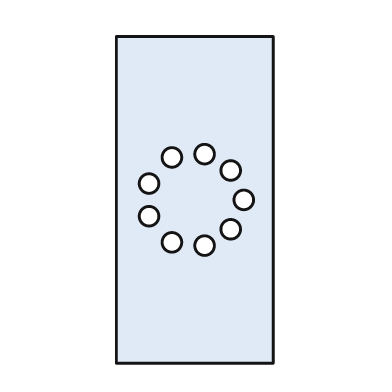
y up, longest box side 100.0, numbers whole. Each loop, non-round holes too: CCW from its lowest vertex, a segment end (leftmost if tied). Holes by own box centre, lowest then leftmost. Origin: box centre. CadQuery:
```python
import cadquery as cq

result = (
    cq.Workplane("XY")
    .moveTo(-24.0, -50.0)
    .lineTo(24.0, -50.0)
    .lineTo(24.0, 50.0)
    .lineTo(-24.0, 50.0)
    .close()
    .moveTo(3.0, -14.0)
    .circle(3.0)
    .moveTo(-7.0, -13.0)
    .circle(3.0)
    .moveTo(11.0, -9.0)
    .circle(3.0)
    .moveTo(-14.0, -5.0)
    .circle(3.0)
    .moveTo(15.0, 0.0)
    .circle(3.0)
    .moveTo(-14.0, 5.0)
    .circle(3.0)
    .moveTo(11.0, 9.0)
    .circle(3.0)
    .moveTo(-7.0, 13.0)
    .circle(3.0)
    .moveTo(3.0, 14.0)
    .circle(3.0)
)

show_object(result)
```